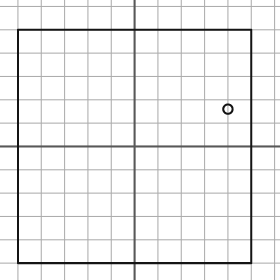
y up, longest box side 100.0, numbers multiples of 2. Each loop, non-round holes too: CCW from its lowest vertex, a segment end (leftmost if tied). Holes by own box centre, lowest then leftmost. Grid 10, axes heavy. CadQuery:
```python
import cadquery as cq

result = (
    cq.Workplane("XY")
    .moveTo(-50.0, -50.0)
    .lineTo(50.0, -50.0)
    .lineTo(50.0, 50.0)
    .lineTo(-50.0, 50.0)
    .close()
    .moveTo(40.0, 16.0)
    .circle(2.0)
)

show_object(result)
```